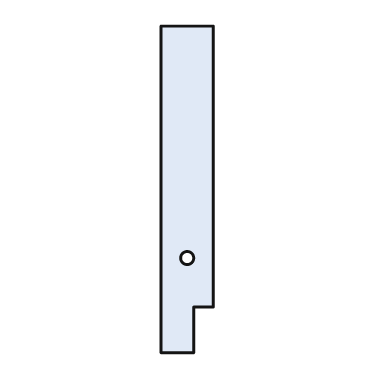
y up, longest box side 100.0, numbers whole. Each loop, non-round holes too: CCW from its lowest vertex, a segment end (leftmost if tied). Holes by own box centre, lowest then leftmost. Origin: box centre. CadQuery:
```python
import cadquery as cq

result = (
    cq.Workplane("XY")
    .moveTo(-8.0, -50.0)
    .lineTo(2.0, -50.0)
    .lineTo(2.0, -36.0)
    .lineTo(8.0, -36.0)
    .lineTo(8.0, 50.0)
    .lineTo(-8.0, 50.0)
    .close()
    .moveTo(0.0, -21.0)
    .circle(2.0)
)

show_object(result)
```